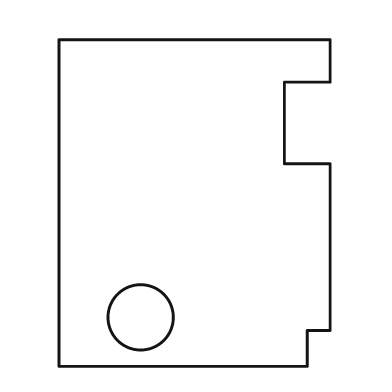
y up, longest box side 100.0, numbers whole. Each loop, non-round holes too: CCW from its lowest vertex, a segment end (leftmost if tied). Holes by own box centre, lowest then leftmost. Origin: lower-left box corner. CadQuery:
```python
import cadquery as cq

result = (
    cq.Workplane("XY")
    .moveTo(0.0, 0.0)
    .lineTo(76.0, 0.0)
    .lineTo(76.0, 11.0)
    .lineTo(83.0, 11.0)
    .lineTo(83.0, 62.0)
    .lineTo(69.0, 62.0)
    .lineTo(69.0, 87.0)
    .lineTo(83.0, 87.0)
    .lineTo(83.0, 100.0)
    .lineTo(0.0, 100.0)
    .close()
    .moveTo(25.0, 15.0)
    .circle(10.0)
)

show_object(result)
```